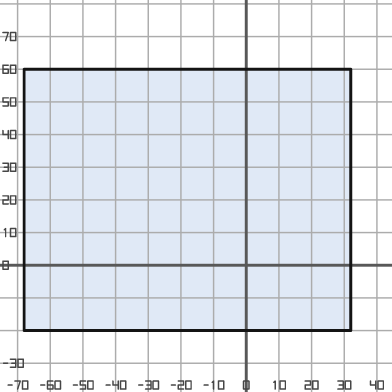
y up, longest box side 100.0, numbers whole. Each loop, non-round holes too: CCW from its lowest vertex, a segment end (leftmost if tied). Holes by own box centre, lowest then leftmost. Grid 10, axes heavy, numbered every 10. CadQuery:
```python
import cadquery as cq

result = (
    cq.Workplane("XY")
    .moveTo(-68.0, -20.0)
    .lineTo(32.0, -20.0)
    .lineTo(32.0, 60.0)
    .lineTo(-68.0, 60.0)
    .close()
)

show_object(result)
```